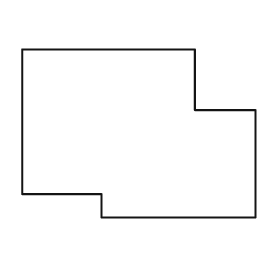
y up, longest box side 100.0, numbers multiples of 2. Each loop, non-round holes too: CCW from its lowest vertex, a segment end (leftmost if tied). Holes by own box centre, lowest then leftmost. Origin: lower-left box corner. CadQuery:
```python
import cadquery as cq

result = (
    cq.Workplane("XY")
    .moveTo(34.0, 0.0)
    .lineTo(100.0, 0.0)
    .lineTo(100.0, 46.0)
    .lineTo(74.0, 46.0)
    .lineTo(74.0, 72.0)
    .lineTo(0.0, 72.0)
    .lineTo(0.0, 10.0)
    .lineTo(34.0, 10.0)
    .close()
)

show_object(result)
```